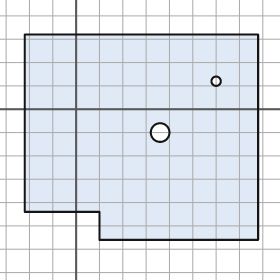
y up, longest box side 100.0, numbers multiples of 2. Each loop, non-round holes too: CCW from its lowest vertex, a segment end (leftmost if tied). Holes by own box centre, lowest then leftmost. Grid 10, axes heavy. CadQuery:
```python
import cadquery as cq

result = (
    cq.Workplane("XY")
    .moveTo(10.0, -56.0)
    .lineTo(78.0, -56.0)
    .lineTo(78.0, 32.0)
    .lineTo(-22.0, 32.0)
    .lineTo(-22.0, -44.0)
    .lineTo(10.0, -44.0)
    .close()
    .moveTo(36.0, -10.0)
    .circle(4.0)
    .moveTo(60.0, 12.0)
    .circle(2.0)
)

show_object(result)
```